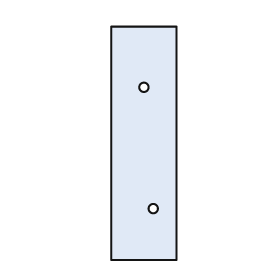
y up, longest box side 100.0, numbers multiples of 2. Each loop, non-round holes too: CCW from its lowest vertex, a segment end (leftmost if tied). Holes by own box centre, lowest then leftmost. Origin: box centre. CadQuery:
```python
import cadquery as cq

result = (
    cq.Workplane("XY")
    .moveTo(-14.0, -50.0)
    .lineTo(14.0, -50.0)
    .lineTo(14.0, 50.0)
    .lineTo(-14.0, 50.0)
    .close()
    .moveTo(4.0, -28.0)
    .circle(2.0)
    .moveTo(0.0, 24.0)
    .circle(2.0)
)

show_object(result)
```